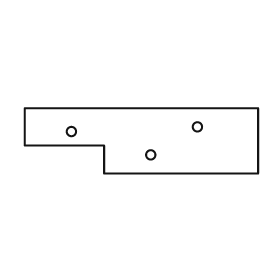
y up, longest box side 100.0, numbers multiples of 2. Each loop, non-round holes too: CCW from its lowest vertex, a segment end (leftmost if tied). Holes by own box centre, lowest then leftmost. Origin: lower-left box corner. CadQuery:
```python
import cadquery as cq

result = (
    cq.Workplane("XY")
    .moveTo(34.0, 0.0)
    .lineTo(100.0, 0.0)
    .lineTo(100.0, 28.0)
    .lineTo(0.0, 28.0)
    .lineTo(0.0, 12.0)
    .lineTo(34.0, 12.0)
    .close()
    .moveTo(54.0, 8.0)
    .circle(2.0)
    .moveTo(20.0, 18.0)
    .circle(2.0)
    .moveTo(74.0, 20.0)
    .circle(2.0)
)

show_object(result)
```